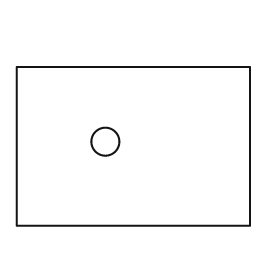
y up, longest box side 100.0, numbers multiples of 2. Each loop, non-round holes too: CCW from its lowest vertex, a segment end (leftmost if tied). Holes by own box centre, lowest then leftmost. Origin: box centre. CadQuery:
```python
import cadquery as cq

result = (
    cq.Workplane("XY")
    .moveTo(-50.0, -34.0)
    .lineTo(50.0, -34.0)
    .lineTo(50.0, 34.0)
    .lineTo(-50.0, 34.0)
    .close()
    .moveTo(-12.0, 2.0)
    .circle(6.0)
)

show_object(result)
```